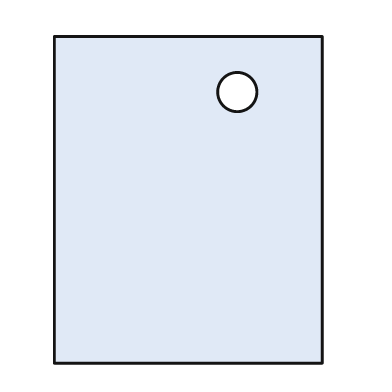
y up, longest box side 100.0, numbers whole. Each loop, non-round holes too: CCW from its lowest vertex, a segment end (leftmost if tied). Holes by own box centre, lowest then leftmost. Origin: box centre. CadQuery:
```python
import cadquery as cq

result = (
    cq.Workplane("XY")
    .moveTo(-41.0, -50.0)
    .lineTo(41.0, -50.0)
    .lineTo(41.0, 50.0)
    .lineTo(-41.0, 50.0)
    .close()
    .moveTo(15.0, 33.0)
    .circle(6.0)
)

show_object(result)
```